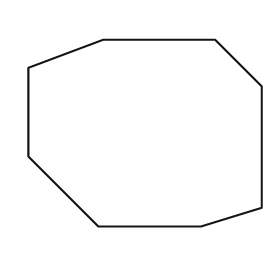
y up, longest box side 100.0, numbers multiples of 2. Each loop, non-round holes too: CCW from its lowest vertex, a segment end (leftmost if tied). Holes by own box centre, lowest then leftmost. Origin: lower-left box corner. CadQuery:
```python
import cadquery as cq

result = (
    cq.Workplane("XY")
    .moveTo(30.0, 0.0)
    .lineTo(74.0, 0.0)
    .lineTo(100.0, 8.0)
    .lineTo(100.0, 60.0)
    .lineTo(80.0, 80.0)
    .lineTo(32.0, 80.0)
    .lineTo(0.0, 68.0)
    .lineTo(0.0, 30.0)
    .close()
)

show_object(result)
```